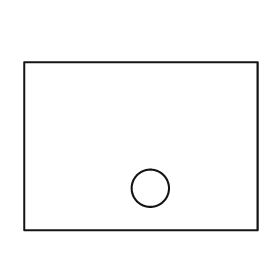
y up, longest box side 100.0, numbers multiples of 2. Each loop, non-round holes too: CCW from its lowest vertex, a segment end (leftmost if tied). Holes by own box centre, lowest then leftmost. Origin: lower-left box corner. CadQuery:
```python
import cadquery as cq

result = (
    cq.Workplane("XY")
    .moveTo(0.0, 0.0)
    .lineTo(100.0, 0.0)
    .lineTo(100.0, 72.0)
    .lineTo(0.0, 72.0)
    .close()
    .moveTo(54.0, 18.0)
    .circle(8.0)
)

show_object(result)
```